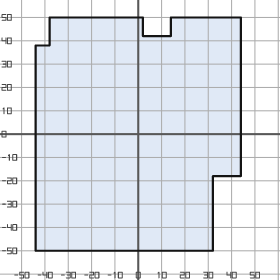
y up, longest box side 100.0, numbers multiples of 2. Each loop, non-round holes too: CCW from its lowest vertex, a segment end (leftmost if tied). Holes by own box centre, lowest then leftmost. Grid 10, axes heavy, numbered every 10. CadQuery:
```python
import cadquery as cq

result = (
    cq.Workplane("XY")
    .moveTo(-44.0, -50.0)
    .lineTo(32.0, -50.0)
    .lineTo(32.0, -18.0)
    .lineTo(44.0, -18.0)
    .lineTo(44.0, 50.0)
    .lineTo(14.0, 50.0)
    .lineTo(14.0, 42.0)
    .lineTo(2.0, 42.0)
    .lineTo(2.0, 50.0)
    .lineTo(-38.0, 50.0)
    .lineTo(-38.0, 38.0)
    .lineTo(-44.0, 38.0)
    .close()
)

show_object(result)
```